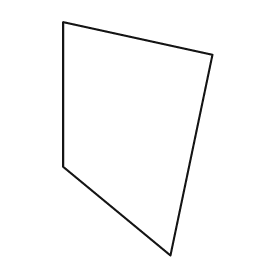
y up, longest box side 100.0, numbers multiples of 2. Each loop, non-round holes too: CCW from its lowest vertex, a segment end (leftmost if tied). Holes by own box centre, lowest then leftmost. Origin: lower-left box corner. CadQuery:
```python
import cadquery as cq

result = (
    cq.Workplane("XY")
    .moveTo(46.0, 0.0)
    .lineTo(64.0, 86.0)
    .lineTo(0.0, 100.0)
    .lineTo(0.0, 38.0)
    .close()
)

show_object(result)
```